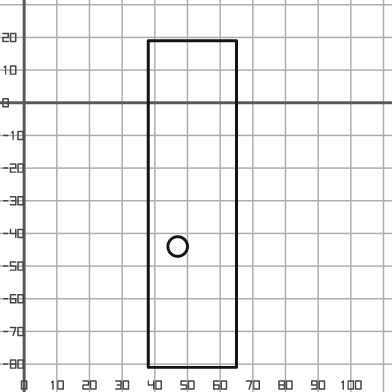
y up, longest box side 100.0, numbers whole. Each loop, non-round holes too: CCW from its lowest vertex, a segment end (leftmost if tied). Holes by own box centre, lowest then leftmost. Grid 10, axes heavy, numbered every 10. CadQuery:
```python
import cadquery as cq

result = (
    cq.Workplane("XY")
    .moveTo(38.0, -81.0)
    .lineTo(65.0, -81.0)
    .lineTo(65.0, 19.0)
    .lineTo(38.0, 19.0)
    .close()
    .moveTo(47.0, -44.0)
    .circle(3.0)
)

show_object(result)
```